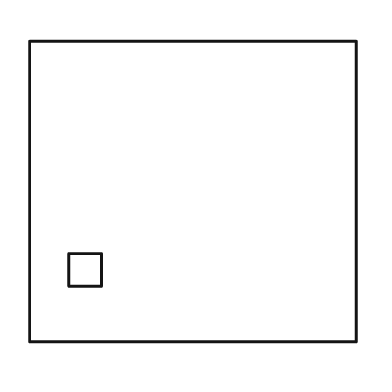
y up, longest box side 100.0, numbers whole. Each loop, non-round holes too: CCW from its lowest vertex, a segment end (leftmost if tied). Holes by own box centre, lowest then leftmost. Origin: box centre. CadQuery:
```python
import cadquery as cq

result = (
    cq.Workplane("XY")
    .moveTo(-50.0, -46.0)
    .lineTo(50.0, -46.0)
    .lineTo(50.0, 46.0)
    .lineTo(-50.0, 46.0)
    .close()
    .moveTo(-38.0, -29.0)
    .lineTo(-28.0, -29.0)
    .lineTo(-28.0, -19.0)
    .lineTo(-38.0, -19.0)
    .close()
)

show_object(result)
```